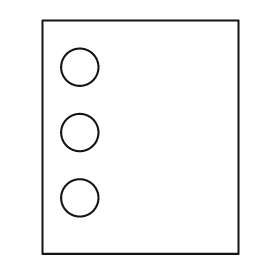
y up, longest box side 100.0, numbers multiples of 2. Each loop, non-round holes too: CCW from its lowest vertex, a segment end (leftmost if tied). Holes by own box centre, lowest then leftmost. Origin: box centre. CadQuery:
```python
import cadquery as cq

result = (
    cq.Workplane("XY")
    .moveTo(-42.0, -50.0)
    .lineTo(42.0, -50.0)
    .lineTo(42.0, 50.0)
    .lineTo(-42.0, 50.0)
    .close()
    .moveTo(-26.0, -26.0)
    .circle(8.0)
    .moveTo(-26.0, 2.0)
    .circle(8.0)
    .moveTo(-26.0, 30.0)
    .circle(8.0)
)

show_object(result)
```